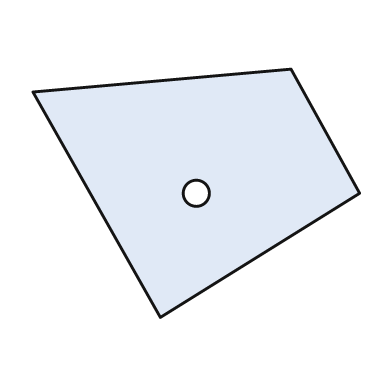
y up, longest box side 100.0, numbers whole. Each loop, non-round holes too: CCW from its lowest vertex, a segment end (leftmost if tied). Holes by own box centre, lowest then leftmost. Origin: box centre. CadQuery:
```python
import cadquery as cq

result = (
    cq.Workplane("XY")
    .moveTo(-11.0, -38.0)
    .lineTo(50.0, 0.0)
    .lineTo(29.0, 38.0)
    .lineTo(-50.0, 31.0)
    .close()
    .moveTo(0.0, 0.0)
    .circle(4.0)
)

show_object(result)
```